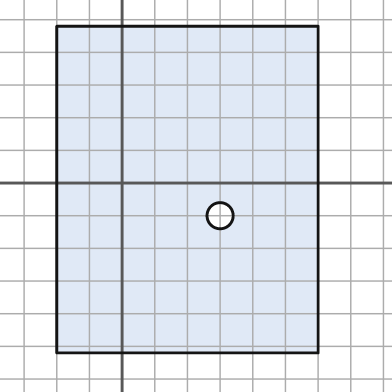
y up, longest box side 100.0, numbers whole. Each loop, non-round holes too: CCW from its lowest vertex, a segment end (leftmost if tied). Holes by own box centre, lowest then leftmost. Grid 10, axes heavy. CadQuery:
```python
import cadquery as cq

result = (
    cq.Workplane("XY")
    .moveTo(-20.0, -52.0)
    .lineTo(60.0, -52.0)
    .lineTo(60.0, 48.0)
    .lineTo(-20.0, 48.0)
    .close()
    .moveTo(30.0, -10.0)
    .circle(4.0)
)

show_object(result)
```